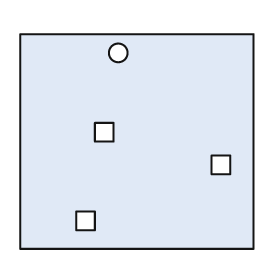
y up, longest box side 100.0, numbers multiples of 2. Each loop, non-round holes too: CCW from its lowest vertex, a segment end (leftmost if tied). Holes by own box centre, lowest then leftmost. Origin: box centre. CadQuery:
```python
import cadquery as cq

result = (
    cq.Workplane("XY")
    .moveTo(-50.0, -46.0)
    .lineTo(50.0, -46.0)
    .lineTo(50.0, 46.0)
    .lineTo(-50.0, 46.0)
    .close()
    .moveTo(-26.0, -38.0)
    .lineTo(-18.0, -38.0)
    .lineTo(-18.0, -30.0)
    .lineTo(-26.0, -30.0)
    .close()
    .moveTo(32.0, -14.0)
    .lineTo(40.0, -14.0)
    .lineTo(40.0, -6.0)
    .lineTo(32.0, -6.0)
    .close()
    .moveTo(-18.0, 0.0)
    .lineTo(-10.0, 0.0)
    .lineTo(-10.0, 8.0)
    .lineTo(-18.0, 8.0)
    .close()
    .moveTo(-8.0, 38.0)
    .circle(4.0)
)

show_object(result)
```